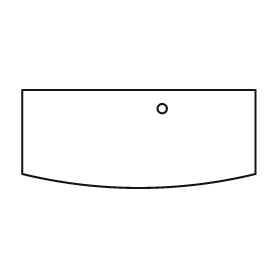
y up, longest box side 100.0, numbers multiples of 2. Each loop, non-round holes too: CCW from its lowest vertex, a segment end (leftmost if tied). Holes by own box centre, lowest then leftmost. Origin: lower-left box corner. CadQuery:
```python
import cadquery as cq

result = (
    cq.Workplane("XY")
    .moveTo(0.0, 6.0)
    .threePointArc((50.0, 0.0), (100.0, 6.0))
    .lineTo(100.0, 42.0)
    .lineTo(0.0, 42.0)
    .close()
    .moveTo(60.0, 34.0)
    .circle(2.0)
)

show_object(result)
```